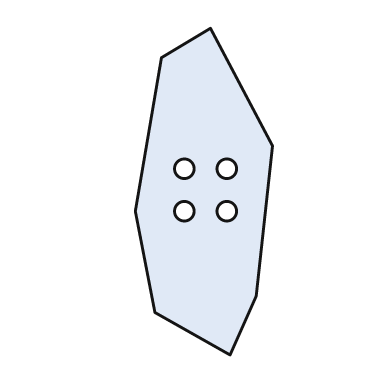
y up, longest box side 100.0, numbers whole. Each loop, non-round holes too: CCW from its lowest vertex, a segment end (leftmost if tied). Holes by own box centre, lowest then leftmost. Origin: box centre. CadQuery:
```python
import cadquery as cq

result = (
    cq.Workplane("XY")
    .moveTo(8.0, -50.0)
    .lineTo(16.0, -32.0)
    .lineTo(21.0, 14.0)
    .lineTo(2.0, 50.0)
    .lineTo(-13.0, 41.0)
    .lineTo(-21.0, -6.0)
    .lineTo(-15.0, -37.0)
    .close()
    .moveTo(-6.0, -6.0)
    .circle(3.0)
    .moveTo(7.0, -6.0)
    .circle(3.0)
    .moveTo(-6.0, 7.0)
    .circle(3.0)
    .moveTo(7.0, 7.0)
    .circle(3.0)
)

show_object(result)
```